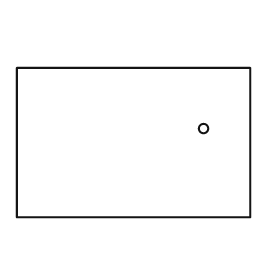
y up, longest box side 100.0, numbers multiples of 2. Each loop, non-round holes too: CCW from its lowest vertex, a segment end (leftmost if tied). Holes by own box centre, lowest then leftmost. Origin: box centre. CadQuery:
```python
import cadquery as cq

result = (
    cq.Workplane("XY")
    .moveTo(-50.0, -32.0)
    .lineTo(50.0, -32.0)
    .lineTo(50.0, 32.0)
    .lineTo(-50.0, 32.0)
    .close()
    .moveTo(30.0, 6.0)
    .circle(2.0)
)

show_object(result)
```